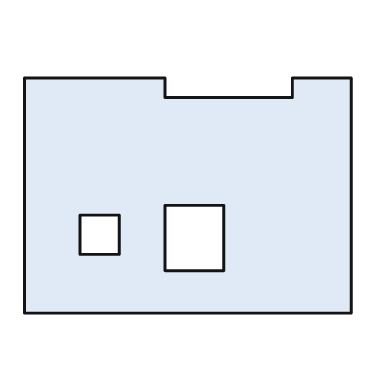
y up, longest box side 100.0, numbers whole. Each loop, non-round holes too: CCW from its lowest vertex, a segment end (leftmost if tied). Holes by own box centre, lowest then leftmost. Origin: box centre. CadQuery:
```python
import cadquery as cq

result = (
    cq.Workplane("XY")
    .moveTo(-50.0, -36.0)
    .lineTo(50.0, -36.0)
    .lineTo(50.0, 36.0)
    .lineTo(32.0, 36.0)
    .lineTo(32.0, 30.0)
    .lineTo(-7.0, 30.0)
    .lineTo(-7.0, 36.0)
    .lineTo(-50.0, 36.0)
    .close()
    .moveTo(-7.0, -23.0)
    .lineTo(11.0, -23.0)
    .lineTo(11.0, -3.0)
    .lineTo(-7.0, -3.0)
    .close()
    .moveTo(-33.0, -18.0)
    .lineTo(-21.0, -18.0)
    .lineTo(-21.0, -6.0)
    .lineTo(-33.0, -6.0)
    .close()
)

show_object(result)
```